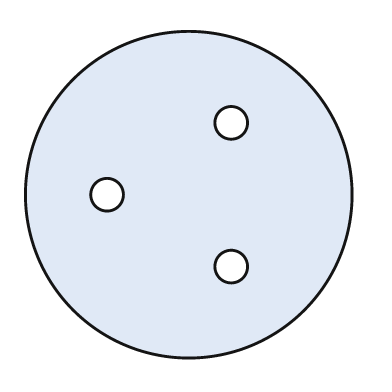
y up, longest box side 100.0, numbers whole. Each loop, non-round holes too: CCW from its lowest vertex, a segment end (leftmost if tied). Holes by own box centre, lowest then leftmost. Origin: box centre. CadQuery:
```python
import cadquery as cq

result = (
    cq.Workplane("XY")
    .moveTo(0.0, 0.0)
    .circle(50.0)
    .moveTo(13.0, -22.0)
    .circle(5.0)
    .moveTo(-25.0, 0.0)
    .circle(5.0)
    .moveTo(13.0, 22.0)
    .circle(5.0)
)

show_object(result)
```